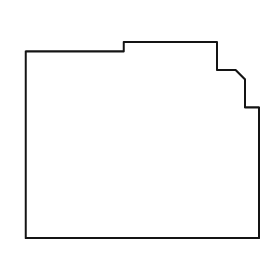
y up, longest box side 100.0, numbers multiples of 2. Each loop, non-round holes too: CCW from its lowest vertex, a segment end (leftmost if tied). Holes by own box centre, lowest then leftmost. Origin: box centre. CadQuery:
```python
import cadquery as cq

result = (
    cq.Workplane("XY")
    .moveTo(-50.0, -42.0)
    .lineTo(50.0, -42.0)
    .lineTo(50.0, 14.0)
    .lineTo(44.0, 14.0)
    .lineTo(44.0, 26.0)
    .lineTo(40.0, 30.0)
    .lineTo(32.0, 30.0)
    .lineTo(32.0, 42.0)
    .lineTo(-8.0, 42.0)
    .lineTo(-8.0, 38.0)
    .lineTo(-50.0, 38.0)
    .close()
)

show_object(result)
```